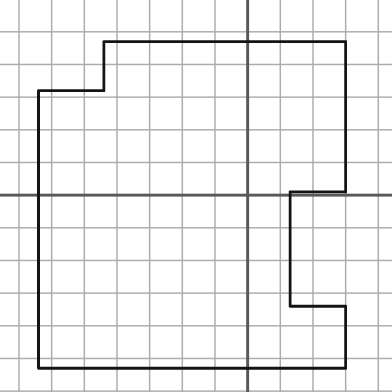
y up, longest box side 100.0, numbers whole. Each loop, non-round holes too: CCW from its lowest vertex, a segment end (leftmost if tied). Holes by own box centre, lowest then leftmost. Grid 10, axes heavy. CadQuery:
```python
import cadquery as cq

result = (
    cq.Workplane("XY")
    .moveTo(-64.0, -53.0)
    .lineTo(30.0, -53.0)
    .lineTo(30.0, -34.0)
    .lineTo(13.0, -34.0)
    .lineTo(13.0, 1.0)
    .lineTo(30.0, 1.0)
    .lineTo(30.0, 47.0)
    .lineTo(-44.0, 47.0)
    .lineTo(-44.0, 32.0)
    .lineTo(-64.0, 32.0)
    .close()
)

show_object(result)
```